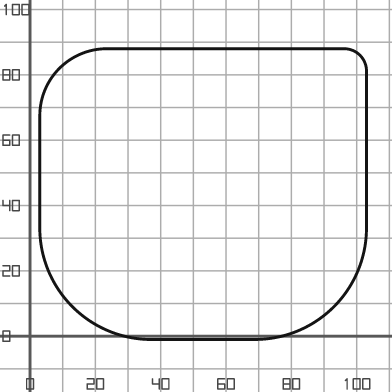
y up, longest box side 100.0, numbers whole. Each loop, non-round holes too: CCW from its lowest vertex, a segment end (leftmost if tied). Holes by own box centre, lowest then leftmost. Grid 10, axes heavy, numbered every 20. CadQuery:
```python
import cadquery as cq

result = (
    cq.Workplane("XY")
    .moveTo(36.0, -1.0)
    .lineTo(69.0, -1.0)
    .threePointArc((93.0, 9.0), (103.0, 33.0))
    .lineTo(103.0, 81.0)
    .threePointArc((101.0, 86.0), (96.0, 88.0))
    .lineTo(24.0, 88.0)
    .threePointArc((9.0, 82.0), (3.0, 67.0))
    .lineTo(3.0, 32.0)
    .threePointArc((13.0, 9.0), (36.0, -1.0))
    .close()
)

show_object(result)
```